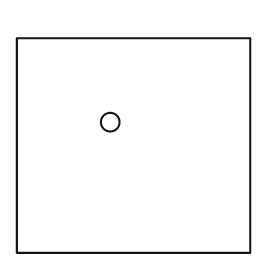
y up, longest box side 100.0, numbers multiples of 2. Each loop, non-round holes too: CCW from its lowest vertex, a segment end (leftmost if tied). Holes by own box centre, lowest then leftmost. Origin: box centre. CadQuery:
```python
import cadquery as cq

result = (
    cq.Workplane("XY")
    .moveTo(-50.0, -46.0)
    .lineTo(50.0, -46.0)
    .lineTo(50.0, 46.0)
    .lineTo(-50.0, 46.0)
    .close()
    .moveTo(-10.0, 10.0)
    .circle(4.0)
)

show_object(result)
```